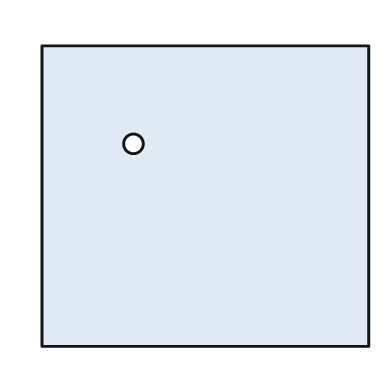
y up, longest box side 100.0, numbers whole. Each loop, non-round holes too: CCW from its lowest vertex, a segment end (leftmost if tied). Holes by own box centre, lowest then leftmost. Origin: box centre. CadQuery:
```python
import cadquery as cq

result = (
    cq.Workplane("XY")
    .moveTo(-50.0, -46.0)
    .lineTo(50.0, -46.0)
    .lineTo(50.0, 46.0)
    .lineTo(-50.0, 46.0)
    .close()
    .moveTo(-22.0, 16.0)
    .circle(3.0)
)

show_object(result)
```